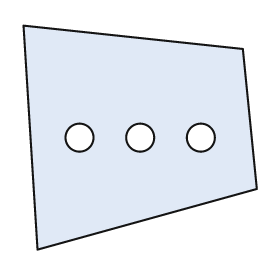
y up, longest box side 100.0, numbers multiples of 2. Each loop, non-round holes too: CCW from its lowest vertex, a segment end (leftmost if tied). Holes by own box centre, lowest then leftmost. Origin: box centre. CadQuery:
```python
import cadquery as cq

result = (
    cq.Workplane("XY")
    .moveTo(-44.0, -48.0)
    .lineTo(50.0, -22.0)
    .lineTo(44.0, 38.0)
    .lineTo(-50.0, 48.0)
    .close()
    .moveTo(-26.0, 0.0)
    .circle(6.0)
    .moveTo(0.0, 0.0)
    .circle(6.0)
    .moveTo(26.0, 0.0)
    .circle(6.0)
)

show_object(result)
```